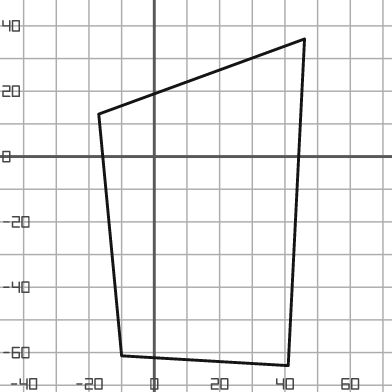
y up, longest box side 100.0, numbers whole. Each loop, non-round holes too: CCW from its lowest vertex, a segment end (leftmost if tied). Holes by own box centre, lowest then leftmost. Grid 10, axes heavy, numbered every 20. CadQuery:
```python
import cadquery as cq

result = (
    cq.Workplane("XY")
    .moveTo(41.0, -64.0)
    .lineTo(46.0, 36.0)
    .lineTo(-17.0, 13.0)
    .lineTo(-10.0, -61.0)
    .close()
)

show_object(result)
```